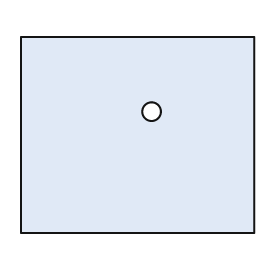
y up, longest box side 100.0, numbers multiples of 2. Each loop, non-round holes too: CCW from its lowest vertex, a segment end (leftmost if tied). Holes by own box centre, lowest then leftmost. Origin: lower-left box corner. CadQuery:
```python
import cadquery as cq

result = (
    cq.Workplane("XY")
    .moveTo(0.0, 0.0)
    .lineTo(100.0, 0.0)
    .lineTo(100.0, 84.0)
    .lineTo(0.0, 84.0)
    .close()
    .moveTo(56.0, 52.0)
    .circle(4.0)
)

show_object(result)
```